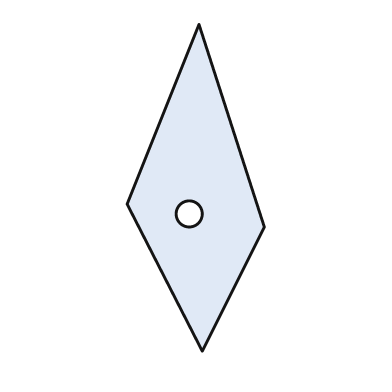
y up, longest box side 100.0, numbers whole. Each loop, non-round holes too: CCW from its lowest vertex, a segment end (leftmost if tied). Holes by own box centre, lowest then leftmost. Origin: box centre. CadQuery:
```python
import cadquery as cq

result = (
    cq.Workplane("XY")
    .moveTo(2.0, -50.0)
    .lineTo(21.0, -12.0)
    .lineTo(1.0, 50.0)
    .lineTo(-21.0, -5.0)
    .close()
    .moveTo(-2.0, -8.0)
    .circle(4.0)
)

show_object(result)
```